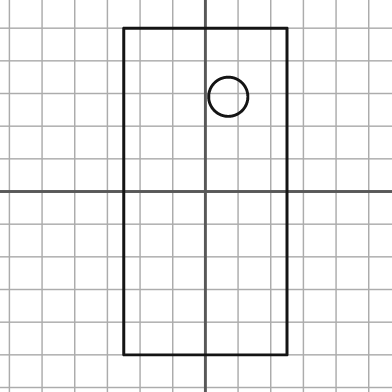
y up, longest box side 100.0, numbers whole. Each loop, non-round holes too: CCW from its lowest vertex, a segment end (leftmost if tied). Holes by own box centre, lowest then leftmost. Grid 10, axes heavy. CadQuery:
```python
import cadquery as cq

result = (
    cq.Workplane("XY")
    .moveTo(-25.0, -50.0)
    .lineTo(25.0, -50.0)
    .lineTo(25.0, 50.0)
    .lineTo(-25.0, 50.0)
    .close()
    .moveTo(7.0, 29.0)
    .circle(6.0)
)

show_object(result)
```